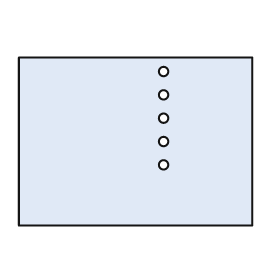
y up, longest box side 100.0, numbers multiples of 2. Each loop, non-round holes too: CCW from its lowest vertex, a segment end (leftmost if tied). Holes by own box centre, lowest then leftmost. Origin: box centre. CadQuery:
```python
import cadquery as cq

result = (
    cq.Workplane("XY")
    .moveTo(-50.0, -36.0)
    .lineTo(50.0, -36.0)
    .lineTo(50.0, 36.0)
    .lineTo(-50.0, 36.0)
    .close()
    .moveTo(12.0, -10.0)
    .circle(2.0)
    .moveTo(12.0, 0.0)
    .circle(2.0)
    .moveTo(12.0, 10.0)
    .circle(2.0)
    .moveTo(12.0, 20.0)
    .circle(2.0)
    .moveTo(12.0, 30.0)
    .circle(2.0)
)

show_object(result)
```